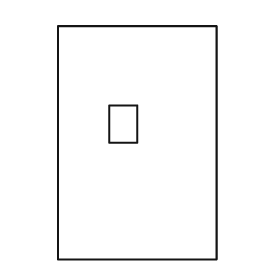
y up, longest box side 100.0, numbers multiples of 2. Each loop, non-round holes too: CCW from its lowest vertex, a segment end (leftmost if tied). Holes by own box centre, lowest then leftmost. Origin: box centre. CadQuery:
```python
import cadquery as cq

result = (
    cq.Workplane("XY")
    .moveTo(-34.0, -50.0)
    .lineTo(34.0, -50.0)
    .lineTo(34.0, 50.0)
    .lineTo(-34.0, 50.0)
    .close()
    .moveTo(-12.0, 0.0)
    .lineTo(0.0, 0.0)
    .lineTo(0.0, 16.0)
    .lineTo(-12.0, 16.0)
    .close()
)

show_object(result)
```